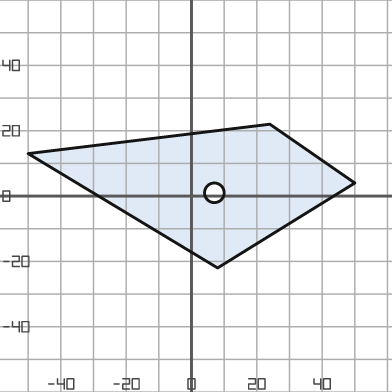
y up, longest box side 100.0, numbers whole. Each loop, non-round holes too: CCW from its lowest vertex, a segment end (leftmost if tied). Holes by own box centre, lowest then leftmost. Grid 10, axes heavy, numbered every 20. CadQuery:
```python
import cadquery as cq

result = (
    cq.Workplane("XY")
    .moveTo(8.0, -22.0)
    .lineTo(50.0, 4.0)
    .lineTo(24.0, 22.0)
    .lineTo(-50.0, 13.0)
    .close()
    .moveTo(7.0, 1.0)
    .circle(3.0)
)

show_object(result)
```